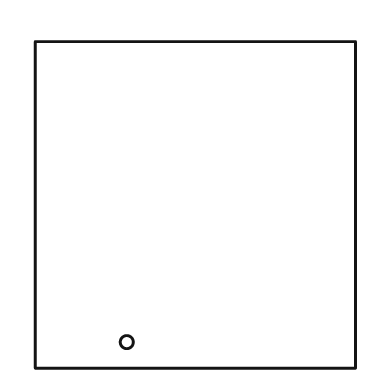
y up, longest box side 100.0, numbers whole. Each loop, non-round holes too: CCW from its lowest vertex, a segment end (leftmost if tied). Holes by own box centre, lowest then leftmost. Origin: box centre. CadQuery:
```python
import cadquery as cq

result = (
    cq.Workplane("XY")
    .moveTo(-49.0, -50.0)
    .lineTo(49.0, -50.0)
    .lineTo(49.0, 50.0)
    .lineTo(-49.0, 50.0)
    .close()
    .moveTo(-21.0, -42.0)
    .circle(2.0)
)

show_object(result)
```